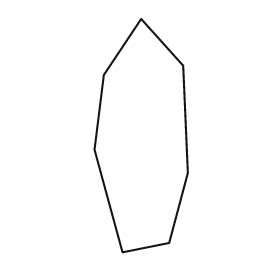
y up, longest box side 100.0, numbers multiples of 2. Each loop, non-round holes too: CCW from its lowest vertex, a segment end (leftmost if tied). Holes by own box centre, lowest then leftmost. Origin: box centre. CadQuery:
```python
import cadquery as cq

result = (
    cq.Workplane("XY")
    .moveTo(-8.0, -50.0)
    .lineTo(12.0, -46.0)
    .lineTo(20.0, -16.0)
    .lineTo(18.0, 30.0)
    .lineTo(0.0, 50.0)
    .lineTo(-16.0, 26.0)
    .lineTo(-20.0, -6.0)
    .close()
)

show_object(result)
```